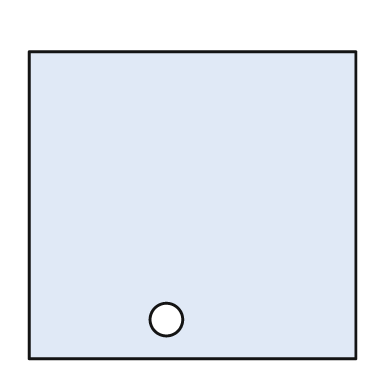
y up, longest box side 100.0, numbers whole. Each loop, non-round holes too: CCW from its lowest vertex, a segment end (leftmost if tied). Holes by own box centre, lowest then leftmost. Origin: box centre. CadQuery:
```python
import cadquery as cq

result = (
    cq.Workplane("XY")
    .moveTo(-50.0, -47.0)
    .lineTo(50.0, -47.0)
    .lineTo(50.0, 47.0)
    .lineTo(-50.0, 47.0)
    .close()
    .moveTo(-8.0, -35.0)
    .circle(5.0)
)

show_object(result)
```